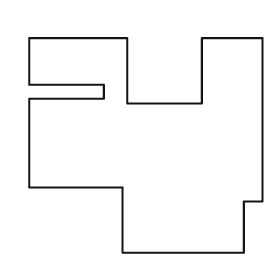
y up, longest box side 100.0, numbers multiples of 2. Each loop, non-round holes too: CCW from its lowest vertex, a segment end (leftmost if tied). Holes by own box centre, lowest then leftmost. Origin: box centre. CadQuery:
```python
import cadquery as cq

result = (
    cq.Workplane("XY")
    .moveTo(-10.0, -46.0)
    .lineTo(42.0, -46.0)
    .lineTo(42.0, -24.0)
    .lineTo(50.0, -24.0)
    .lineTo(50.0, 46.0)
    .lineTo(24.0, 46.0)
    .lineTo(24.0, 18.0)
    .lineTo(-8.0, 18.0)
    .lineTo(-8.0, 46.0)
    .lineTo(-50.0, 46.0)
    .lineTo(-50.0, 26.0)
    .lineTo(-18.0, 26.0)
    .lineTo(-18.0, 20.0)
    .lineTo(-50.0, 20.0)
    .lineTo(-50.0, -18.0)
    .lineTo(-10.0, -18.0)
    .close()
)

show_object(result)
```